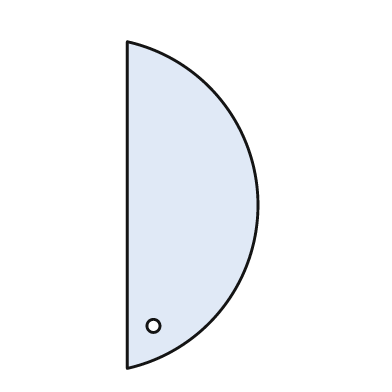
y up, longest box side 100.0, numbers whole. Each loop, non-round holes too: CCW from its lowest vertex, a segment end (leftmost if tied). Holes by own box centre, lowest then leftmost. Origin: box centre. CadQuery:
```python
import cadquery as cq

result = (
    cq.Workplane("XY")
    .moveTo(-20.0, -50.0)
    .threePointArc((20.0, 0.0), (-20.0, 50.0))
    .close()
    .moveTo(-12.0, -37.0)
    .circle(2.0)
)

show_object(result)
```